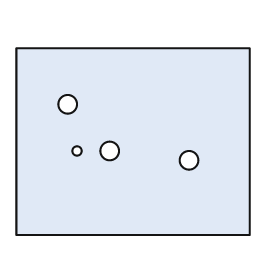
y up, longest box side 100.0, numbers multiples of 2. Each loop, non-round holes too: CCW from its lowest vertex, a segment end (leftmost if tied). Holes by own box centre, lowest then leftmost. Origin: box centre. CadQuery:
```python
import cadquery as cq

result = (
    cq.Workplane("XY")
    .moveTo(-50.0, -40.0)
    .lineTo(50.0, -40.0)
    .lineTo(50.0, 40.0)
    .lineTo(-50.0, 40.0)
    .close()
    .moveTo(24.0, -8.0)
    .circle(4.0)
    .moveTo(-24.0, -4.0)
    .circle(2.0)
    .moveTo(-10.0, -4.0)
    .circle(4.0)
    .moveTo(-28.0, 16.0)
    .circle(4.0)
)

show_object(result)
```